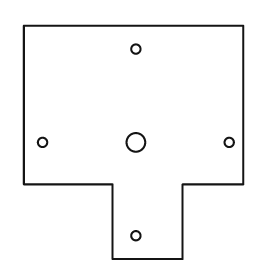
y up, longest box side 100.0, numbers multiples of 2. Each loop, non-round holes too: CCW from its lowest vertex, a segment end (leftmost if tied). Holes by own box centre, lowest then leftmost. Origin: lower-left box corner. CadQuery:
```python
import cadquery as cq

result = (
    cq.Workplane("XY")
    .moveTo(38.0, 0.0)
    .lineTo(68.0, 0.0)
    .lineTo(68.0, 32.0)
    .lineTo(94.0, 32.0)
    .lineTo(94.0, 100.0)
    .lineTo(0.0, 100.0)
    .lineTo(0.0, 32.0)
    .lineTo(38.0, 32.0)
    .close()
    .moveTo(48.0, 10.0)
    .circle(2.0)
    .moveTo(8.0, 50.0)
    .circle(2.0)
    .moveTo(48.0, 50.0)
    .circle(4.0)
    .moveTo(88.0, 50.0)
    .circle(2.0)
    .moveTo(48.0, 90.0)
    .circle(2.0)
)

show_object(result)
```